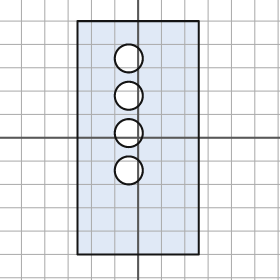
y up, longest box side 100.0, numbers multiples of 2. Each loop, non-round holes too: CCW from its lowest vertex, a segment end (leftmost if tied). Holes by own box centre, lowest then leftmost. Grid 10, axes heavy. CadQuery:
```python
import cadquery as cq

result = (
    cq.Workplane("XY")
    .moveTo(-26.0, -50.0)
    .lineTo(26.0, -50.0)
    .lineTo(26.0, 50.0)
    .lineTo(-26.0, 50.0)
    .close()
    .moveTo(-4.0, -14.0)
    .circle(6.0)
    .moveTo(-4.0, 2.0)
    .circle(6.0)
    .moveTo(-4.0, 18.0)
    .circle(6.0)
    .moveTo(-4.0, 34.0)
    .circle(6.0)
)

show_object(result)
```